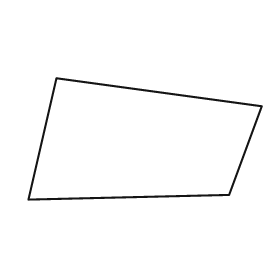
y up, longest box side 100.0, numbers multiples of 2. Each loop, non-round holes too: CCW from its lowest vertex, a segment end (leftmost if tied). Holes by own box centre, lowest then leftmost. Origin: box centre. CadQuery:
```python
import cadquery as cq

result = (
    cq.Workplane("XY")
    .moveTo(-50.0, -26.0)
    .lineTo(36.0, -24.0)
    .lineTo(50.0, 14.0)
    .lineTo(-38.0, 26.0)
    .close()
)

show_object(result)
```